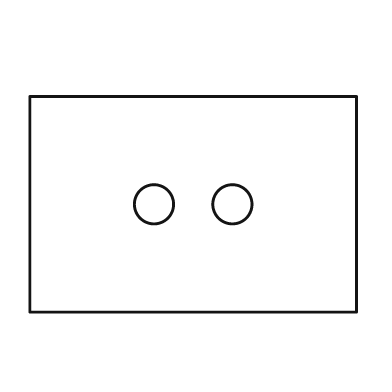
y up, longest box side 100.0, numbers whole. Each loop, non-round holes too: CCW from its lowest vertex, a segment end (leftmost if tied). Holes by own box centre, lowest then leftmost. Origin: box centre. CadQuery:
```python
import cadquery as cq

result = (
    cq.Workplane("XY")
    .moveTo(-50.0, -33.0)
    .lineTo(50.0, -33.0)
    .lineTo(50.0, 33.0)
    .lineTo(-50.0, 33.0)
    .close()
    .moveTo(-12.0, 0.0)
    .circle(6.0)
    .moveTo(12.0, 0.0)
    .circle(6.0)
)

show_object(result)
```